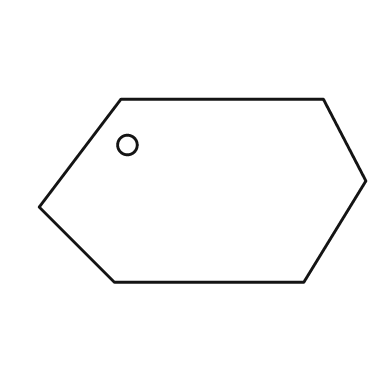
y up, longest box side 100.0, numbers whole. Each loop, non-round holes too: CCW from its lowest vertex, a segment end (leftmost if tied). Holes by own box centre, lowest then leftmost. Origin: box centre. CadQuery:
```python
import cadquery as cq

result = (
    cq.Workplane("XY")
    .moveTo(-27.0, -28.0)
    .lineTo(31.0, -28.0)
    .lineTo(50.0, 3.0)
    .lineTo(37.0, 28.0)
    .lineTo(-25.0, 28.0)
    .lineTo(-50.0, -5.0)
    .close()
    .moveTo(-23.0, 14.0)
    .circle(3.0)
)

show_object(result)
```